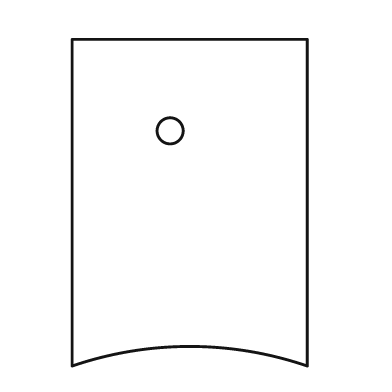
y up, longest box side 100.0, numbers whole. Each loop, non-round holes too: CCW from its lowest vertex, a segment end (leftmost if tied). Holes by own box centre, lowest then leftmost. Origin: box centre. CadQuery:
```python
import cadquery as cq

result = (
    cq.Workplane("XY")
    .moveTo(-36.0, -50.0)
    .threePointArc((0.0, -44.0), (36.0, -50.0))
    .lineTo(36.0, 50.0)
    .lineTo(-36.0, 50.0)
    .close()
    .moveTo(-6.0, 22.0)
    .circle(4.0)
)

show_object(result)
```